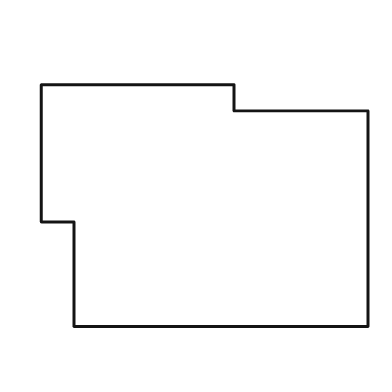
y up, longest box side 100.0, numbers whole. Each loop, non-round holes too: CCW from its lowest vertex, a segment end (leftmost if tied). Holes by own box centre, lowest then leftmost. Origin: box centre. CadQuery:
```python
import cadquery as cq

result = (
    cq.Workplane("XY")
    .moveTo(-40.0, -37.0)
    .lineTo(50.0, -37.0)
    .lineTo(50.0, 29.0)
    .lineTo(9.0, 29.0)
    .lineTo(9.0, 37.0)
    .lineTo(-50.0, 37.0)
    .lineTo(-50.0, -5.0)
    .lineTo(-40.0, -5.0)
    .close()
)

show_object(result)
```